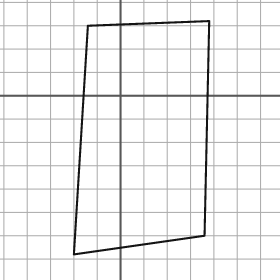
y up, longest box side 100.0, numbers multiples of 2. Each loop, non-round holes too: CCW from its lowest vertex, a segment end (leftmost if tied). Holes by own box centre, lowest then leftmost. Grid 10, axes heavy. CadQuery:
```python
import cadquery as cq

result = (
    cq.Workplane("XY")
    .moveTo(-20.0, -68.0)
    .lineTo(36.0, -60.0)
    .lineTo(38.0, 32.0)
    .lineTo(-14.0, 30.0)
    .close()
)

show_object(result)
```